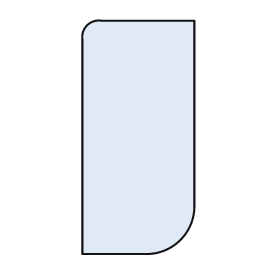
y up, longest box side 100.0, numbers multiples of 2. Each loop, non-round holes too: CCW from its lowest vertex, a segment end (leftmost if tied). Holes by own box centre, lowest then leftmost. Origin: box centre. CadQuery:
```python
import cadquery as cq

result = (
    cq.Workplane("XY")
    .moveTo(-24.0, -50.0)
    .lineTo(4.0, -50.0)
    .threePointArc((18.0, -44.0), (24.0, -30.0))
    .lineTo(24.0, 50.0)
    .lineTo(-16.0, 50.0)
    .threePointArc((-22.0, 48.0), (-24.0, 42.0))
    .close()
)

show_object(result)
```